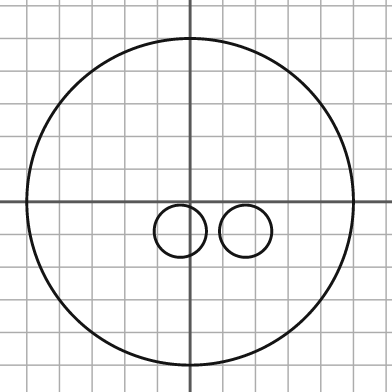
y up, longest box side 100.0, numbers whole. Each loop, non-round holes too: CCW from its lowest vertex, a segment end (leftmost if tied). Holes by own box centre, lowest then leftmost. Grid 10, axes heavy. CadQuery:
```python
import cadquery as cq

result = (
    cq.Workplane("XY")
    .moveTo(0.0, 0.0)
    .circle(50.0)
    .moveTo(-3.0, -9.0)
    .circle(8.0)
    .moveTo(17.0, -9.0)
    .circle(8.0)
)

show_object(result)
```